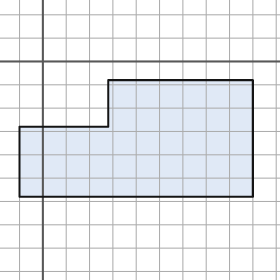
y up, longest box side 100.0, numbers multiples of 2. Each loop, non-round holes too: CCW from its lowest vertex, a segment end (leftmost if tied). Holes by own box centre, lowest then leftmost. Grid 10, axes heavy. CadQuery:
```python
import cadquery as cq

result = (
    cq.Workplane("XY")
    .moveTo(-10.0, -58.0)
    .lineTo(90.0, -58.0)
    .lineTo(90.0, -8.0)
    .lineTo(28.0, -8.0)
    .lineTo(28.0, -28.0)
    .lineTo(-10.0, -28.0)
    .close()
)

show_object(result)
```